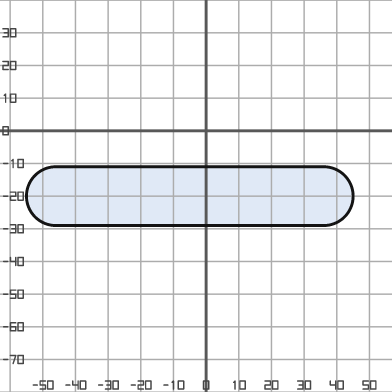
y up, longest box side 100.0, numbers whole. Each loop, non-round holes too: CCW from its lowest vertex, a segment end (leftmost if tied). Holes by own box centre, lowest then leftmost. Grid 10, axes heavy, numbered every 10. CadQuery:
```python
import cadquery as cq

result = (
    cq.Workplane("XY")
    .moveTo(-46.0, -29.0)
    .lineTo(36.0, -29.0)
    .threePointArc((45.0, -20.0), (36.0, -11.0))
    .lineTo(-46.0, -11.0)
    .threePointArc((-55.0, -20.0), (-46.0, -29.0))
    .close()
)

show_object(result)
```